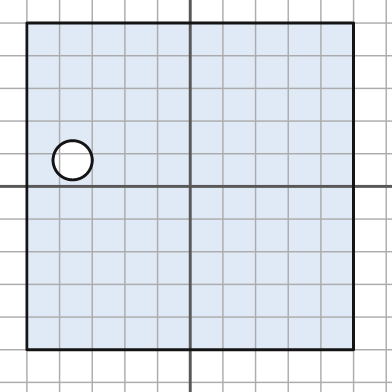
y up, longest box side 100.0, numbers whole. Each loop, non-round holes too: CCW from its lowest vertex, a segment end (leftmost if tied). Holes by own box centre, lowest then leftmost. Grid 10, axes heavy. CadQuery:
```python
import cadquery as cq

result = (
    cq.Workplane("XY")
    .moveTo(-50.0, -50.0)
    .lineTo(50.0, -50.0)
    .lineTo(50.0, 50.0)
    .lineTo(-50.0, 50.0)
    .close()
    .moveTo(-36.0, 8.0)
    .circle(6.0)
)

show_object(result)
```